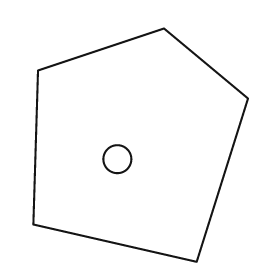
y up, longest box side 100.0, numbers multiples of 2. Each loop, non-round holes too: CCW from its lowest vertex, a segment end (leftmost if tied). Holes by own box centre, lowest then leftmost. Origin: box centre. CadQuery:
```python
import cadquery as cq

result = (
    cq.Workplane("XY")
    .moveTo(24.0, -50.0)
    .lineTo(46.0, 20.0)
    .lineTo(10.0, 50.0)
    .lineTo(-44.0, 32.0)
    .lineTo(-46.0, -34.0)
    .close()
    .moveTo(-10.0, -6.0)
    .circle(6.0)
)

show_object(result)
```